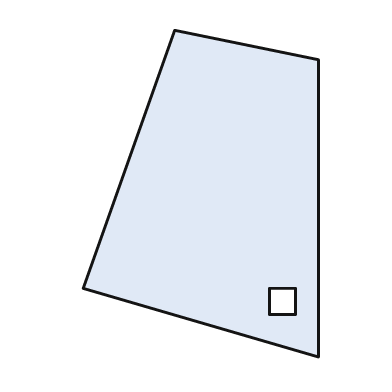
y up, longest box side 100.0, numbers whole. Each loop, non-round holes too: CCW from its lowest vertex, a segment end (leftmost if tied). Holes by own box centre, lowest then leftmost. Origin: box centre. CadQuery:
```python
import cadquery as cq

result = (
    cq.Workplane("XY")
    .moveTo(36.0, -50.0)
    .lineTo(36.0, 41.0)
    .lineTo(-8.0, 50.0)
    .lineTo(-36.0, -29.0)
    .close()
    .moveTo(21.0, -37.0)
    .lineTo(29.0, -37.0)
    .lineTo(29.0, -29.0)
    .lineTo(21.0, -29.0)
    .close()
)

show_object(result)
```